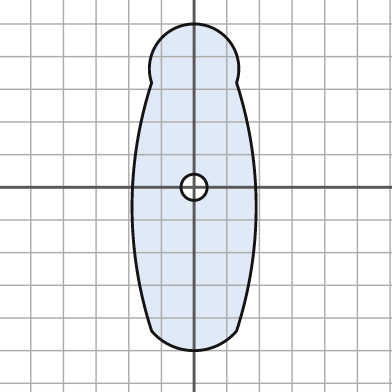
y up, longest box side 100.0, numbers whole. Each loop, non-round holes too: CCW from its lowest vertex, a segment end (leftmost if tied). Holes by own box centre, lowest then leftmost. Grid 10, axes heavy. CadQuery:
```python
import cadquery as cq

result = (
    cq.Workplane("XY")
    .moveTo(-13.0, -44.0)
    .threePointArc((0.0, -50.0), (13.0, -44.0))
    .threePointArc((19.0, -6.0), (13.0, 32.0))
    .threePointArc((0.0, 50.0), (-13.0, 32.0))
    .threePointArc((-19.0, -6.0), (-13.0, -44.0))
    .close()
    .moveTo(0.0, 0.0)
    .circle(4.0)
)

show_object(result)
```